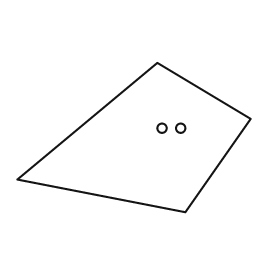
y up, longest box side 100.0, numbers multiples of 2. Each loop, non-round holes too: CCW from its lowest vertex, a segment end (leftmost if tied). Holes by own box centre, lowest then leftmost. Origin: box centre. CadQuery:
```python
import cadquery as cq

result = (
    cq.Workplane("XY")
    .moveTo(22.0, -32.0)
    .lineTo(50.0, 8.0)
    .lineTo(10.0, 32.0)
    .lineTo(-50.0, -18.0)
    .close()
    .moveTo(12.0, 4.0)
    .circle(2.0)
    .moveTo(20.0, 4.0)
    .circle(2.0)
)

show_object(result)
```